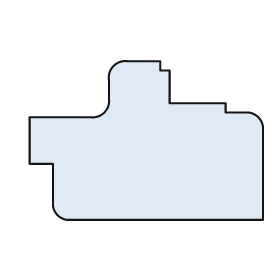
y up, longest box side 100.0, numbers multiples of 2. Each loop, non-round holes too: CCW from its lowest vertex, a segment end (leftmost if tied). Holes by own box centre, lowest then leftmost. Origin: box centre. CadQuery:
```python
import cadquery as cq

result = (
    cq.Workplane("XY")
    .moveTo(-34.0, -34.0)
    .lineTo(50.0, -34.0)
    .lineTo(50.0, 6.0)
    .threePointArc((48.0, 10.0), (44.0, 12.0))
    .lineTo(34.0, 12.0)
    .lineTo(34.0, 16.0)
    .lineTo(10.0, 16.0)
    .lineTo(10.0, 30.0)
    .lineTo(6.0, 30.0)
    .lineTo(6.0, 34.0)
    .lineTo(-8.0, 34.0)
    .threePointArc((-14.0, 32.0), (-16.0, 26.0))
    .lineTo(-16.0, 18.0)
    .threePointArc((-18.0, 12.0), (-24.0, 10.0))
    .lineTo(-50.0, 10.0)
    .lineTo(-50.0, -10.0)
    .lineTo(-40.0, -10.0)
    .lineTo(-40.0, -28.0)
    .threePointArc((-38.0, -32.0), (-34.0, -34.0))
    .close()
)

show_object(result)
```